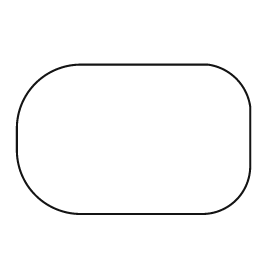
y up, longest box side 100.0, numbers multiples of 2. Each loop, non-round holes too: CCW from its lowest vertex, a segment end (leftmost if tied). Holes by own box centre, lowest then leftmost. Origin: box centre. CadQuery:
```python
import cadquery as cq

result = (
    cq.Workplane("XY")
    .moveTo(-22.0, -32.0)
    .lineTo(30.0, -32.0)
    .threePointArc((44.0, -26.0), (50.0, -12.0))
    .lineTo(50.0, 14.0)
    .threePointArc((44.0, 26.0), (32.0, 32.0))
    .lineTo(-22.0, 32.0)
    .threePointArc((-42.0, 24.0), (-50.0, 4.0))
    .lineTo(-50.0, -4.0)
    .threePointArc((-42.0, -24.0), (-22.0, -32.0))
    .close()
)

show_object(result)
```